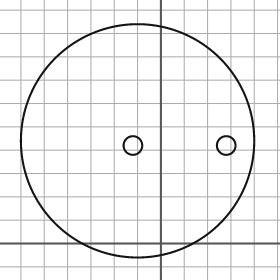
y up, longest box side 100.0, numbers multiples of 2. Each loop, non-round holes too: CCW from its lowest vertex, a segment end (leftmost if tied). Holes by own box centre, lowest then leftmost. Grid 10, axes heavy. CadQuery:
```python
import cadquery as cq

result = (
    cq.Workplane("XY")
    .moveTo(-10.0, 44.0)
    .circle(50.0)
    .moveTo(-12.0, 42.0)
    .circle(4.0)
    .moveTo(28.0, 42.0)
    .circle(4.0)
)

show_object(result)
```